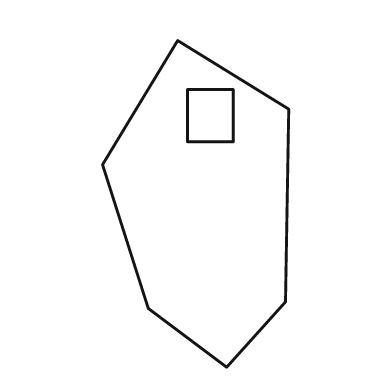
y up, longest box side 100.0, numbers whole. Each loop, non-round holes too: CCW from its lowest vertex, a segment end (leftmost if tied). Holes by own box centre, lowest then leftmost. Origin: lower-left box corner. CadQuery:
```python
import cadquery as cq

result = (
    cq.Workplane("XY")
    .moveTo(38.0, 0.0)
    .lineTo(56.0, 20.0)
    .lineTo(57.0, 79.0)
    .lineTo(23.0, 100.0)
    .lineTo(0.0, 62.0)
    .lineTo(14.0, 18.0)
    .close()
    .moveTo(26.0, 69.0)
    .lineTo(40.0, 69.0)
    .lineTo(40.0, 85.0)
    .lineTo(26.0, 85.0)
    .close()
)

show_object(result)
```